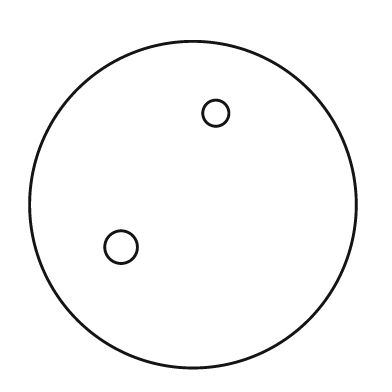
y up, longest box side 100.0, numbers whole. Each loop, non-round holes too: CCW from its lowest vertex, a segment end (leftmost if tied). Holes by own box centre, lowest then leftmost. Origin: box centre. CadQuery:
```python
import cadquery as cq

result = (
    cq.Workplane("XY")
    .moveTo(0.0, 0.0)
    .circle(50.0)
    .moveTo(-22.0, -13.0)
    .circle(5.0)
    .moveTo(7.0, 28.0)
    .circle(4.0)
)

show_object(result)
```